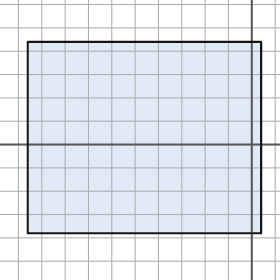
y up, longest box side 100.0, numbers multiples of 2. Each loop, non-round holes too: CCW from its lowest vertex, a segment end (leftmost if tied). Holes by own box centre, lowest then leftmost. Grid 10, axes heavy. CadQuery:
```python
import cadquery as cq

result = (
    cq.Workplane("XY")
    .moveTo(-96.0, -38.0)
    .lineTo(4.0, -38.0)
    .lineTo(4.0, 44.0)
    .lineTo(-96.0, 44.0)
    .close()
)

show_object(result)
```